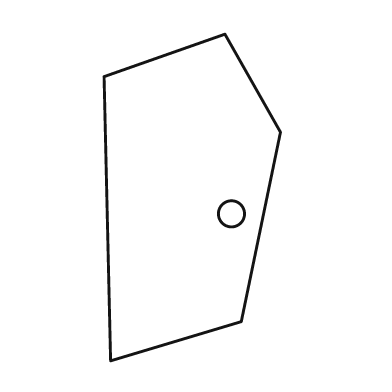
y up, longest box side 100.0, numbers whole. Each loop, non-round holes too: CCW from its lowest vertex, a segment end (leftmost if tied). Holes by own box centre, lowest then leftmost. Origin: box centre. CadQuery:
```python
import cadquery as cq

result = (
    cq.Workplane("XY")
    .moveTo(-25.0, -50.0)
    .lineTo(15.0, -38.0)
    .lineTo(27.0, 20.0)
    .lineTo(10.0, 50.0)
    .lineTo(-27.0, 37.0)
    .close()
    .moveTo(12.0, -5.0)
    .circle(4.0)
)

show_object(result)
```